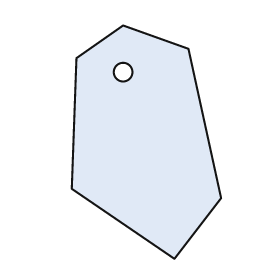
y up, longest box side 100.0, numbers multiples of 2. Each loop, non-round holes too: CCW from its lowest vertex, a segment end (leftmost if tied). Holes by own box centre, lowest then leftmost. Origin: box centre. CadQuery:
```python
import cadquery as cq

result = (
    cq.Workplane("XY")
    .moveTo(12.0, -50.0)
    .lineTo(32.0, -24.0)
    .lineTo(18.0, 40.0)
    .lineTo(-10.0, 50.0)
    .lineTo(-30.0, 36.0)
    .lineTo(-32.0, -20.0)
    .close()
    .moveTo(-10.0, 30.0)
    .circle(4.0)
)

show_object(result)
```